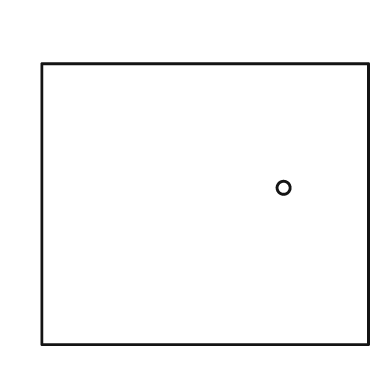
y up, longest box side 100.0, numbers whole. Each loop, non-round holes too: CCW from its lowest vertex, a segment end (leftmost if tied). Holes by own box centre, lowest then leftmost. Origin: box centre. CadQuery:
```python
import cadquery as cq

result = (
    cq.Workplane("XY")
    .moveTo(-50.0, -43.0)
    .lineTo(50.0, -43.0)
    .lineTo(50.0, 43.0)
    .lineTo(-50.0, 43.0)
    .close()
    .moveTo(24.0, 5.0)
    .circle(2.0)
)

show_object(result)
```